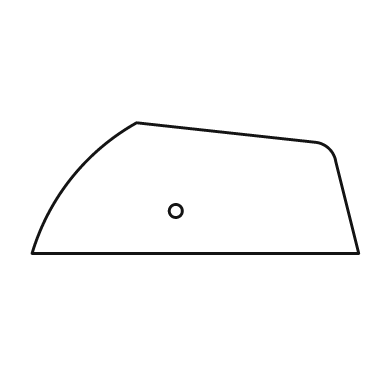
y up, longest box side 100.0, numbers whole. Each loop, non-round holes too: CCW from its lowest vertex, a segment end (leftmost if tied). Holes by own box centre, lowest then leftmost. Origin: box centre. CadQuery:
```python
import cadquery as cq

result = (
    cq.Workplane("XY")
    .moveTo(-50.0, -20.0)
    .lineTo(50.0, -20.0)
    .lineTo(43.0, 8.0)
    .threePointArc((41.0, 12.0), (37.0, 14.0))
    .lineTo(-18.0, 20.0)
    .threePointArc((-38.0, 3.0), (-50.0, -20.0))
    .close()
    .moveTo(-6.0, -7.0)
    .circle(2.0)
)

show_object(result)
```